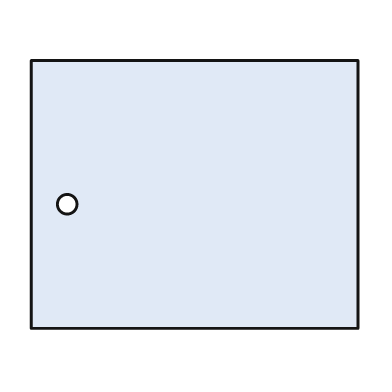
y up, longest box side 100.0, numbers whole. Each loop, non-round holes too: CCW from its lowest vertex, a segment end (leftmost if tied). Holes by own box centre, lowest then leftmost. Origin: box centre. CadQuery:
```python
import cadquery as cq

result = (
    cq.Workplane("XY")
    .moveTo(-50.0, -41.0)
    .lineTo(50.0, -41.0)
    .lineTo(50.0, 41.0)
    .lineTo(-50.0, 41.0)
    .close()
    .moveTo(-39.0, -3.0)
    .circle(3.0)
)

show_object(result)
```